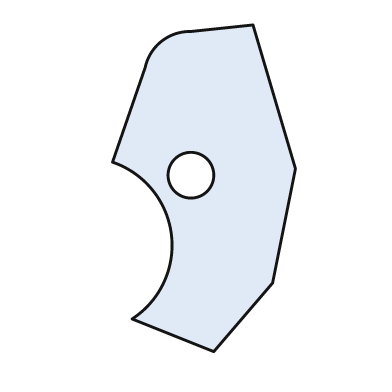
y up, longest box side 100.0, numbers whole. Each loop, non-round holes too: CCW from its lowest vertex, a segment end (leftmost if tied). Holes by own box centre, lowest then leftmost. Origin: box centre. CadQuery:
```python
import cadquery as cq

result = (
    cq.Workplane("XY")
    .moveTo(3.0, -50.0)
    .lineTo(21.0, -29.0)
    .lineTo(28.0, 6.0)
    .lineTo(15.0, 50.0)
    .lineTo(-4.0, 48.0)
    .threePointArc((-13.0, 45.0), (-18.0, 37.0))
    .lineTo(-28.0, 8.0)
    .threePointArc((-10.0, -14.0), (-22.0, -40.0))
    .close()
    .moveTo(-4.0, 4.0)
    .circle(7.0)
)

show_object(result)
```